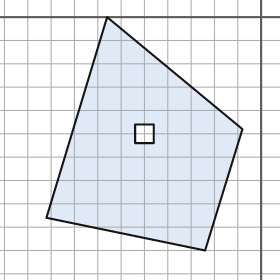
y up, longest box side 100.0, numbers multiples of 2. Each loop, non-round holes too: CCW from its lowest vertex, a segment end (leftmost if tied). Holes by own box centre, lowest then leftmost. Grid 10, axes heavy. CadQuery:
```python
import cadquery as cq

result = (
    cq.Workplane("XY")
    .moveTo(-24.0, -100.0)
    .lineTo(-8.0, -48.0)
    .lineTo(-66.0, 0.0)
    .lineTo(-92.0, -86.0)
    .close()
    .moveTo(-54.0, -54.0)
    .lineTo(-46.0, -54.0)
    .lineTo(-46.0, -46.0)
    .lineTo(-54.0, -46.0)
    .close()
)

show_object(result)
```